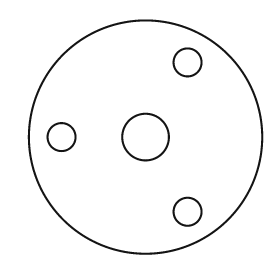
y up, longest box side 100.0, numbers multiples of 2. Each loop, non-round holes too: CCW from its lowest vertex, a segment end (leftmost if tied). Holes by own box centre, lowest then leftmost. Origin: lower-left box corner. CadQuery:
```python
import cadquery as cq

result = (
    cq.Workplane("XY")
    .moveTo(50.0, 50.0)
    .circle(50.0)
    .moveTo(68.0, 18.0)
    .circle(6.0)
    .moveTo(14.0, 50.0)
    .circle(6.0)
    .moveTo(50.0, 50.0)
    .circle(10.0)
    .moveTo(68.0, 82.0)
    .circle(6.0)
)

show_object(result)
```